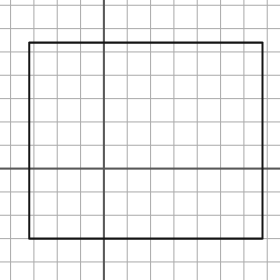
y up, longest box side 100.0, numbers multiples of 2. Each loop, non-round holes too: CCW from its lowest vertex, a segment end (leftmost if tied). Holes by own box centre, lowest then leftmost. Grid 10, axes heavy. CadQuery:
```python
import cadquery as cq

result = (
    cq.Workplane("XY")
    .moveTo(-32.0, -30.0)
    .lineTo(68.0, -30.0)
    .lineTo(68.0, 54.0)
    .lineTo(-32.0, 54.0)
    .close()
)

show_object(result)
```